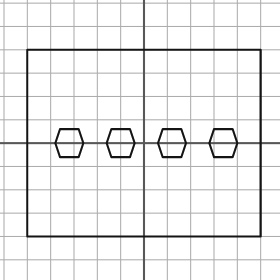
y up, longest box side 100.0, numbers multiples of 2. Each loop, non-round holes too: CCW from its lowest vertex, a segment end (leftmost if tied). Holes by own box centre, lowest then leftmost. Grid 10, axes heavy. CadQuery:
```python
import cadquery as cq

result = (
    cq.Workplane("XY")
    .moveTo(-50.0, -40.0)
    .lineTo(50.0, -40.0)
    .lineTo(50.0, 40.0)
    .lineTo(-50.0, 40.0)
    .close()
    .moveTo(-36.0, -6.0)
    .lineTo(-28.0, -6.0)
    .lineTo(-26.0, 0.0)
    .lineTo(-28.0, 6.0)
    .lineTo(-36.0, 6.0)
    .lineTo(-38.0, 0.0)
    .close()
    .moveTo(-14.0, -6.0)
    .lineTo(-6.0, -6.0)
    .lineTo(-4.0, 0.0)
    .lineTo(-6.0, 6.0)
    .lineTo(-14.0, 6.0)
    .lineTo(-16.0, 0.0)
    .close()
    .moveTo(8.0, -6.0)
    .lineTo(16.0, -6.0)
    .lineTo(18.0, 0.0)
    .lineTo(16.0, 6.0)
    .lineTo(8.0, 6.0)
    .lineTo(6.0, 0.0)
    .close()
    .moveTo(30.0, -6.0)
    .lineTo(38.0, -6.0)
    .lineTo(40.0, 0.0)
    .lineTo(38.0, 6.0)
    .lineTo(30.0, 6.0)
    .lineTo(28.0, 0.0)
    .close()
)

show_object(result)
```